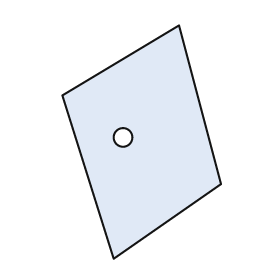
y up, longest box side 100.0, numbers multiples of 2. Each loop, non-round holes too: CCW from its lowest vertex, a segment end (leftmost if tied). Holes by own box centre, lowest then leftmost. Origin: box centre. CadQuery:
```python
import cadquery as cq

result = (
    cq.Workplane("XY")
    .moveTo(-12.0, -50.0)
    .lineTo(34.0, -18.0)
    .lineTo(16.0, 50.0)
    .lineTo(-34.0, 20.0)
    .close()
    .moveTo(-8.0, 2.0)
    .circle(4.0)
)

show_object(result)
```